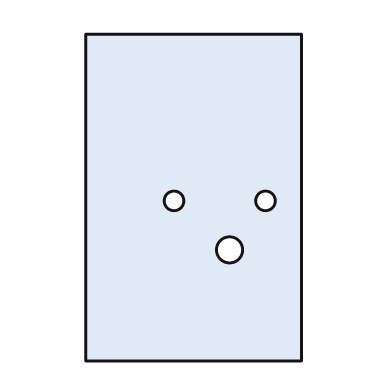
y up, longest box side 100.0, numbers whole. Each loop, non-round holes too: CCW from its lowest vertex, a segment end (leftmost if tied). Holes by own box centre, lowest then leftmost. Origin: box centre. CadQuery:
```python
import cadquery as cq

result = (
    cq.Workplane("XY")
    .moveTo(-33.0, -50.0)
    .lineTo(33.0, -50.0)
    .lineTo(33.0, 50.0)
    .lineTo(-33.0, 50.0)
    .close()
    .moveTo(11.0, -16.0)
    .circle(4.0)
    .moveTo(-6.0, -1.0)
    .circle(3.0)
    .moveTo(22.0, -1.0)
    .circle(3.0)
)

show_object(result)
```